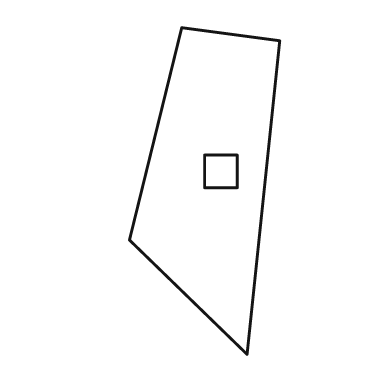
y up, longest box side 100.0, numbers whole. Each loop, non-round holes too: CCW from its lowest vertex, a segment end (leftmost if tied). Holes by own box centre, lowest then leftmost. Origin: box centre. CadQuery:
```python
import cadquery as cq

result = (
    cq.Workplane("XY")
    .moveTo(13.0, -50.0)
    .lineTo(23.0, 46.0)
    .lineTo(-7.0, 50.0)
    .lineTo(-23.0, -15.0)
    .close()
    .moveTo(0.0, 1.0)
    .lineTo(10.0, 1.0)
    .lineTo(10.0, 11.0)
    .lineTo(0.0, 11.0)
    .close()
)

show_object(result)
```